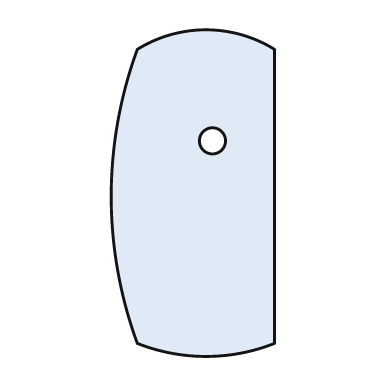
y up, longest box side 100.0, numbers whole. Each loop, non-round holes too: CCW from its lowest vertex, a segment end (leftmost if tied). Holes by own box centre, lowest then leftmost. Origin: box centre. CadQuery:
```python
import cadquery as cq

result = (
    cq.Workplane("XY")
    .moveTo(-17.0, -46.0)
    .threePointArc((4.0, -50.0), (25.0, -46.0))
    .lineTo(25.0, 44.0)
    .threePointArc((4.0, 50.0), (-17.0, 44.0))
    .threePointArc((-25.0, -1.0), (-17.0, -46.0))
    .close()
    .moveTo(6.0, 16.0)
    .circle(4.0)
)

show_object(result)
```